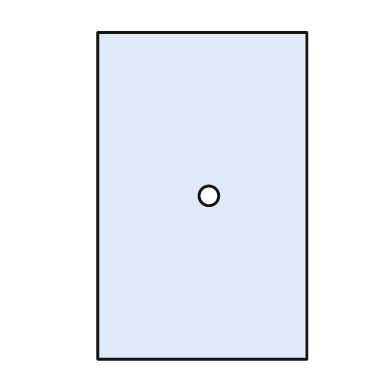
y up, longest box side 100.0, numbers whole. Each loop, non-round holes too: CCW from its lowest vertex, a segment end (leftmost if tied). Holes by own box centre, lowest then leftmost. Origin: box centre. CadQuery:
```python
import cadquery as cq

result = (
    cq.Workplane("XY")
    .moveTo(-32.0, -50.0)
    .lineTo(32.0, -50.0)
    .lineTo(32.0, 50.0)
    .lineTo(-32.0, 50.0)
    .close()
    .moveTo(2.0, 0.0)
    .circle(3.0)
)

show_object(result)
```